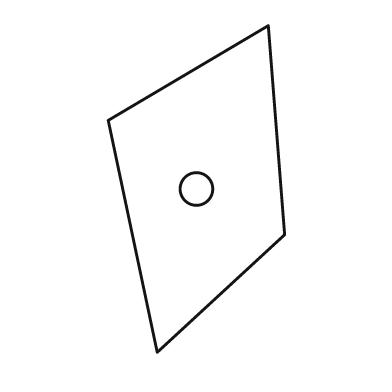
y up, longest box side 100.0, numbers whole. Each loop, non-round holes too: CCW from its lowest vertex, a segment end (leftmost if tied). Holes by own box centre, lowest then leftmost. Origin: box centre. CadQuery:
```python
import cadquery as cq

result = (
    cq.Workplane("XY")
    .moveTo(-12.0, -50.0)
    .lineTo(27.0, -14.0)
    .lineTo(22.0, 50.0)
    .lineTo(-27.0, 21.0)
    .close()
    .moveTo(0.0, 0.0)
    .circle(5.0)
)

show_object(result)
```